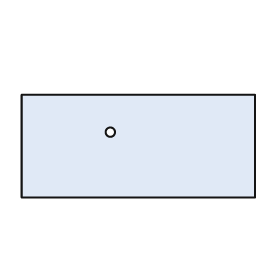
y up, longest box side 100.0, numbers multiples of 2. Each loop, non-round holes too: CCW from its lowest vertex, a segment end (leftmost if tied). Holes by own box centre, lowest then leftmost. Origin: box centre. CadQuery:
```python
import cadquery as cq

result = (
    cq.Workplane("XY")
    .moveTo(-50.0, -22.0)
    .lineTo(50.0, -22.0)
    .lineTo(50.0, 22.0)
    .lineTo(-50.0, 22.0)
    .close()
    .moveTo(-12.0, 6.0)
    .circle(2.0)
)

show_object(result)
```